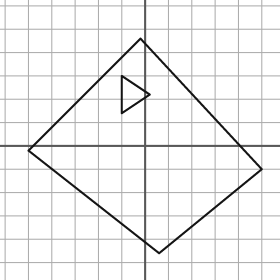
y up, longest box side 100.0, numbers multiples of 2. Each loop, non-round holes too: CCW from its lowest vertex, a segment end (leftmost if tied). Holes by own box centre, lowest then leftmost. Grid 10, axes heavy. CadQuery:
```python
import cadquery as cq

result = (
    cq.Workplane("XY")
    .moveTo(6.0, -46.0)
    .lineTo(50.0, -10.0)
    .lineTo(-2.0, 46.0)
    .lineTo(-50.0, -2.0)
    .close()
    .moveTo(-10.0, 14.0)
    .lineTo(2.0, 22.0)
    .lineTo(-10.0, 30.0)
    .close()
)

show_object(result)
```